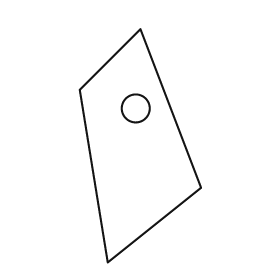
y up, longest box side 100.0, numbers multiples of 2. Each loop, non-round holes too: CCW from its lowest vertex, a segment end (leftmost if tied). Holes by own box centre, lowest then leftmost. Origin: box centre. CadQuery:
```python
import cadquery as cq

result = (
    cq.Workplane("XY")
    .moveTo(-14.0, -50.0)
    .lineTo(26.0, -18.0)
    .lineTo(0.0, 50.0)
    .lineTo(-26.0, 24.0)
    .close()
    .moveTo(-2.0, 16.0)
    .circle(6.0)
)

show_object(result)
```